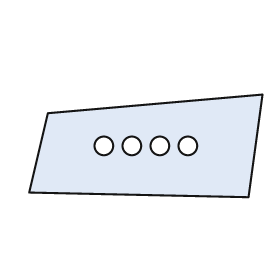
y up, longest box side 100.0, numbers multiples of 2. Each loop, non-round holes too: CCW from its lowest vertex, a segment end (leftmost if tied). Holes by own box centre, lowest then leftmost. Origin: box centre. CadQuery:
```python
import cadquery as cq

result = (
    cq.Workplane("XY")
    .moveTo(44.0, -22.0)
    .lineTo(50.0, 22.0)
    .lineTo(-42.0, 14.0)
    .lineTo(-50.0, -20.0)
    .close()
    .moveTo(-18.0, 0.0)
    .circle(4.0)
    .moveTo(-6.0, 0.0)
    .circle(4.0)
    .moveTo(6.0, 0.0)
    .circle(4.0)
    .moveTo(18.0, 0.0)
    .circle(4.0)
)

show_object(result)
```